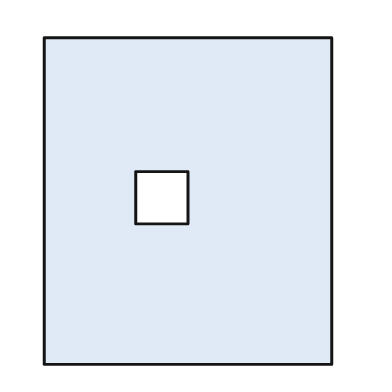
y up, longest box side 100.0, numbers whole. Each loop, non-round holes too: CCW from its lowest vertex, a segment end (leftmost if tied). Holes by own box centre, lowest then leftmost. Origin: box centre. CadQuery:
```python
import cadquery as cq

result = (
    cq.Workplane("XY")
    .moveTo(-44.0, -50.0)
    .lineTo(44.0, -50.0)
    .lineTo(44.0, 50.0)
    .lineTo(-44.0, 50.0)
    .close()
    .moveTo(-16.0, -7.0)
    .lineTo(0.0, -7.0)
    .lineTo(0.0, 9.0)
    .lineTo(-16.0, 9.0)
    .close()
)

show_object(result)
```